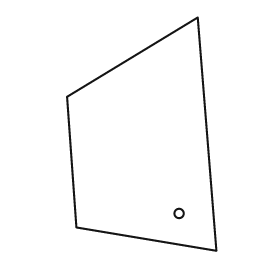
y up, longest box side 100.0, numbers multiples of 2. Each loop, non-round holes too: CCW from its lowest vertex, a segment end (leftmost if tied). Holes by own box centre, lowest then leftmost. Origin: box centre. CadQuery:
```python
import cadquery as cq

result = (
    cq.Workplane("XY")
    .moveTo(32.0, -50.0)
    .lineTo(24.0, 50.0)
    .lineTo(-32.0, 16.0)
    .lineTo(-28.0, -40.0)
    .close()
    .moveTo(16.0, -34.0)
    .circle(2.0)
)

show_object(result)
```